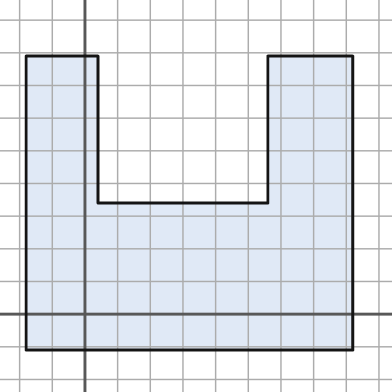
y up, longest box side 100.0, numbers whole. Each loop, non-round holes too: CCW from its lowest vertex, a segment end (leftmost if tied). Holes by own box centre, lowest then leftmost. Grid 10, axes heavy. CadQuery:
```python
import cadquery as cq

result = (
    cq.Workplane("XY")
    .moveTo(-18.0, -11.0)
    .lineTo(82.0, -11.0)
    .lineTo(82.0, 79.0)
    .lineTo(56.0, 79.0)
    .lineTo(56.0, 34.0)
    .lineTo(4.0, 34.0)
    .lineTo(4.0, 79.0)
    .lineTo(-18.0, 79.0)
    .close()
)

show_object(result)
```